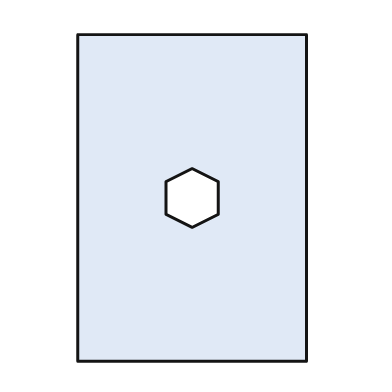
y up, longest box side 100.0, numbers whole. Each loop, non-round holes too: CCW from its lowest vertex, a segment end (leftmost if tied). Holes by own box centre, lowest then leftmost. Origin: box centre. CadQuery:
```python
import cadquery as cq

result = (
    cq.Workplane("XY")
    .moveTo(-35.0, -50.0)
    .lineTo(35.0, -50.0)
    .lineTo(35.0, 50.0)
    .lineTo(-35.0, 50.0)
    .close()
    .moveTo(0.0, -9.0)
    .lineTo(8.0, -5.0)
    .lineTo(8.0, 5.0)
    .lineTo(0.0, 9.0)
    .lineTo(-8.0, 5.0)
    .lineTo(-8.0, -5.0)
    .close()
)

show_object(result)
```